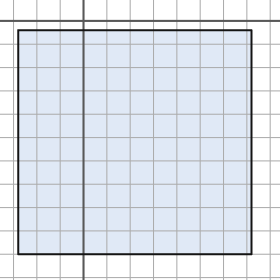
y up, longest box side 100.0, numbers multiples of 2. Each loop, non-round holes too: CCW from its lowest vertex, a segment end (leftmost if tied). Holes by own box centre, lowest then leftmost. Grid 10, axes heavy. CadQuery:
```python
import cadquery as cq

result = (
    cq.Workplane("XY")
    .moveTo(-28.0, -100.0)
    .lineTo(72.0, -100.0)
    .lineTo(72.0, -4.0)
    .lineTo(-28.0, -4.0)
    .close()
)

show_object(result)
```